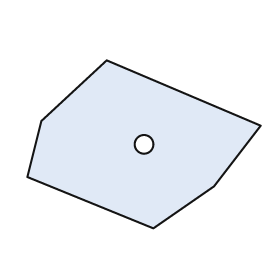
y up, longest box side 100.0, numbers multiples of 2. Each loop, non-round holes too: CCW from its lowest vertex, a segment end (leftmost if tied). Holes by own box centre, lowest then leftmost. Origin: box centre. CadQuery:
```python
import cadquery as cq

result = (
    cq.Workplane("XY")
    .moveTo(4.0, -36.0)
    .lineTo(30.0, -18.0)
    .lineTo(50.0, 8.0)
    .lineTo(-16.0, 36.0)
    .lineTo(-44.0, 10.0)
    .lineTo(-50.0, -14.0)
    .close()
    .moveTo(0.0, 0.0)
    .circle(4.0)
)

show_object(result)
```